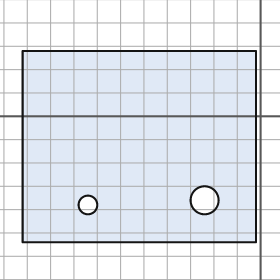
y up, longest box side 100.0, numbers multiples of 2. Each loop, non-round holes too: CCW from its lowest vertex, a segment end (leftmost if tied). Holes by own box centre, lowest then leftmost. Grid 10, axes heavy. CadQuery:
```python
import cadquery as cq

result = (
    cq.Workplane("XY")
    .moveTo(-102.0, -54.0)
    .lineTo(-2.0, -54.0)
    .lineTo(-2.0, 28.0)
    .lineTo(-102.0, 28.0)
    .close()
    .moveTo(-74.0, -38.0)
    .circle(4.0)
    .moveTo(-24.0, -36.0)
    .circle(6.0)
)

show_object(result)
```